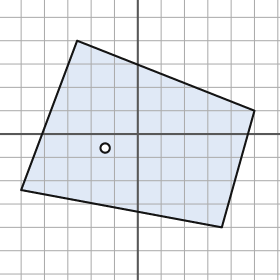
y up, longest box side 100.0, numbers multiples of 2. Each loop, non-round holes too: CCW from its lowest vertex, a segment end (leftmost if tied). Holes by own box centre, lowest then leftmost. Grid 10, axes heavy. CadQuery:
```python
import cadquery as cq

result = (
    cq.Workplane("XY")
    .moveTo(36.0, -40.0)
    .lineTo(50.0, 10.0)
    .lineTo(-26.0, 40.0)
    .lineTo(-50.0, -24.0)
    .close()
    .moveTo(-14.0, -6.0)
    .circle(2.0)
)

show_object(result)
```